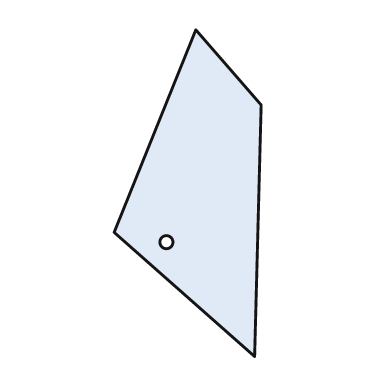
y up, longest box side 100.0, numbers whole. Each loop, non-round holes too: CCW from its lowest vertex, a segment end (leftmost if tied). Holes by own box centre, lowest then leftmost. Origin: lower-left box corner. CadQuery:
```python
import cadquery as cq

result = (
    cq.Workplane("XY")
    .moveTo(43.0, 0.0)
    .lineTo(45.0, 77.0)
    .lineTo(25.0, 100.0)
    .lineTo(0.0, 38.0)
    .close()
    .moveTo(16.0, 35.0)
    .circle(2.0)
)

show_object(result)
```